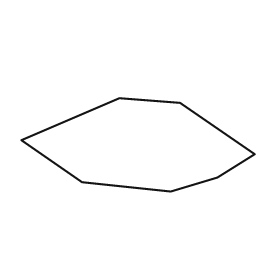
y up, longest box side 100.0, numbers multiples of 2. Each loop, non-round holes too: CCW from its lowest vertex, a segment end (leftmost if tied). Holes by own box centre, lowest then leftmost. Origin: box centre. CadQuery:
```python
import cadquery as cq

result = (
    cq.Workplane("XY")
    .moveTo(14.0, -20.0)
    .lineTo(34.0, -14.0)
    .lineTo(50.0, -4.0)
    .lineTo(18.0, 18.0)
    .lineTo(-8.0, 20.0)
    .lineTo(-50.0, 2.0)
    .lineTo(-24.0, -16.0)
    .close()
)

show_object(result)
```